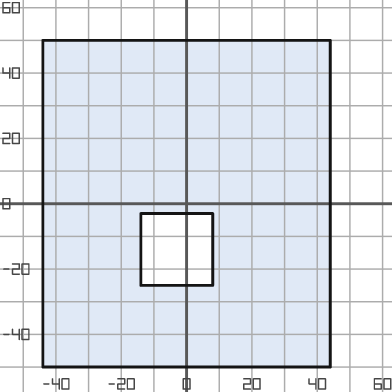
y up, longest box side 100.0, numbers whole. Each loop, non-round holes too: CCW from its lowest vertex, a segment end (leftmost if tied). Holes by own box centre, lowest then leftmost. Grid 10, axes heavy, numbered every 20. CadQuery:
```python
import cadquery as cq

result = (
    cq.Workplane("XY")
    .moveTo(-44.0, -50.0)
    .lineTo(44.0, -50.0)
    .lineTo(44.0, 50.0)
    .lineTo(-44.0, 50.0)
    .close()
    .moveTo(-14.0, -25.0)
    .lineTo(8.0, -25.0)
    .lineTo(8.0, -3.0)
    .lineTo(-14.0, -3.0)
    .close()
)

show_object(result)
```